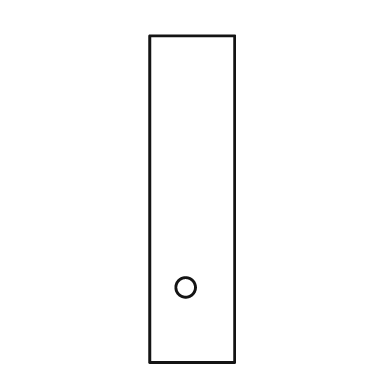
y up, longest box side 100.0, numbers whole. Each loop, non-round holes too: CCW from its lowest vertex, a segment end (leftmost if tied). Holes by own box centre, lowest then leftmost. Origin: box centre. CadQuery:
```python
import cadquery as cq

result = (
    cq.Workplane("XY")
    .moveTo(-13.0, -50.0)
    .lineTo(13.0, -50.0)
    .lineTo(13.0, 50.0)
    .lineTo(-13.0, 50.0)
    .close()
    .moveTo(-2.0, -27.0)
    .circle(3.0)
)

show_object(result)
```